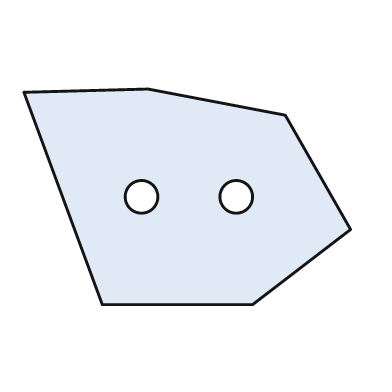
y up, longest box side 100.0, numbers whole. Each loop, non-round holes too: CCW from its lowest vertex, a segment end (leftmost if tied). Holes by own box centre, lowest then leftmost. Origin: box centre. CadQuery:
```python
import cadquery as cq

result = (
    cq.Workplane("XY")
    .moveTo(-26.0, -33.0)
    .lineTo(20.0, -33.0)
    .lineTo(50.0, -10.0)
    .lineTo(30.0, 25.0)
    .lineTo(-12.0, 33.0)
    .lineTo(-50.0, 32.0)
    .close()
    .moveTo(-14.0, 0.0)
    .circle(5.0)
    .moveTo(15.0, 0.0)
    .circle(5.0)
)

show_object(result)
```